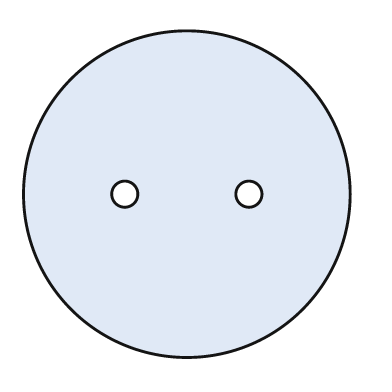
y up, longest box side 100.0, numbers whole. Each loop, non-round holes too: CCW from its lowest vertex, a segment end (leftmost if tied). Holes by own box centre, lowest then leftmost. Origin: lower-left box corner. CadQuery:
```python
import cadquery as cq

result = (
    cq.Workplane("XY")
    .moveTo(50.0, 50.0)
    .circle(50.0)
    .moveTo(31.0, 50.0)
    .circle(4.0)
    .moveTo(69.0, 50.0)
    .circle(4.0)
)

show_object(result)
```